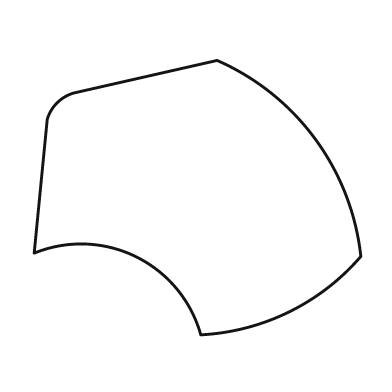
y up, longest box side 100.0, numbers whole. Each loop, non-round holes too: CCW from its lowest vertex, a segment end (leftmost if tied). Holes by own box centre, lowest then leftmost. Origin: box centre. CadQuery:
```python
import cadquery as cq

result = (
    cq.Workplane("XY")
    .moveTo(1.0, -42.0)
    .threePointArc((28.0, -35.0), (50.0, -18.0))
    .threePointArc((36.0, 18.0), (6.0, 42.0))
    .lineTo(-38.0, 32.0)
    .threePointArc((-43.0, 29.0), (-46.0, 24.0))
    .lineTo(-50.0, -17.0)
    .threePointArc((-19.0, -18.0), (1.0, -42.0))
    .close()
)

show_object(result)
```